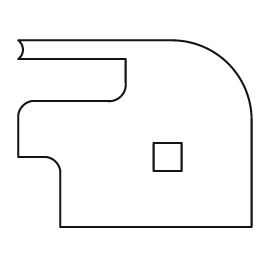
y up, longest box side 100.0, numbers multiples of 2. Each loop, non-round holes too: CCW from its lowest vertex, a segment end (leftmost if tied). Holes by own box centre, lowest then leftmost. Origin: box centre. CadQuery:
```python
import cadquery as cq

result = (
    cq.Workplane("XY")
    .moveTo(-32.0, -40.0)
    .lineTo(50.0, -40.0)
    .lineTo(50.0, 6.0)
    .threePointArc((40.0, 30.0), (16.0, 40.0))
    .lineTo(-50.0, 40.0)
    .threePointArc((-48.0, 36.0), (-50.0, 32.0))
    .lineTo(-4.0, 32.0)
    .lineTo(-4.0, 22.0)
    .threePointArc((-6.0, 16.0), (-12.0, 14.0))
    .lineTo(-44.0, 14.0)
    .threePointArc((-48.0, 12.0), (-50.0, 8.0))
    .lineTo(-50.0, -10.0)
    .lineTo(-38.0, -10.0)
    .threePointArc((-34.0, -12.0), (-32.0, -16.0))
    .close()
    .moveTo(8.0, -16.0)
    .lineTo(20.0, -16.0)
    .lineTo(20.0, -4.0)
    .lineTo(8.0, -4.0)
    .close()
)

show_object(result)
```